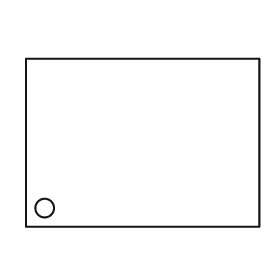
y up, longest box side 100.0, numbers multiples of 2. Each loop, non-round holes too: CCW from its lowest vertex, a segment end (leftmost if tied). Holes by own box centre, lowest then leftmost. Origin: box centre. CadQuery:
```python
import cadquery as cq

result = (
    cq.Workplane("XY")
    .moveTo(-50.0, -36.0)
    .lineTo(50.0, -36.0)
    .lineTo(50.0, 36.0)
    .lineTo(-50.0, 36.0)
    .close()
    .moveTo(-42.0, -28.0)
    .circle(4.0)
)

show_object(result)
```